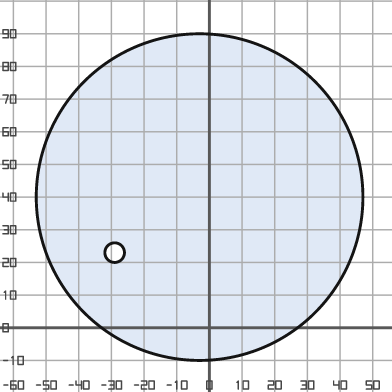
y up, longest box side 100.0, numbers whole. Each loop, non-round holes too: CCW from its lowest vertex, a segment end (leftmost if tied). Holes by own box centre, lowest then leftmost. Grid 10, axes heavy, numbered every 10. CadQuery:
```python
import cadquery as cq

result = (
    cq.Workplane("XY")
    .moveTo(-3.0, 40.0)
    .circle(50.0)
    .moveTo(-29.0, 23.0)
    .circle(3.0)
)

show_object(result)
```